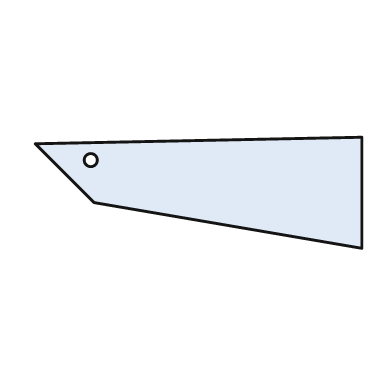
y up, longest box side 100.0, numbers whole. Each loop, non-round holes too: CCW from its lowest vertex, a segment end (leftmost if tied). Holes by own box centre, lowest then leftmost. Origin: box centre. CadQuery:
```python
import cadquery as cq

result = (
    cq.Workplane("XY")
    .moveTo(50.0, -17.0)
    .lineTo(50.0, 17.0)
    .lineTo(-50.0, 15.0)
    .lineTo(-32.0, -3.0)
    .close()
    .moveTo(-33.0, 10.0)
    .circle(2.0)
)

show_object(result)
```